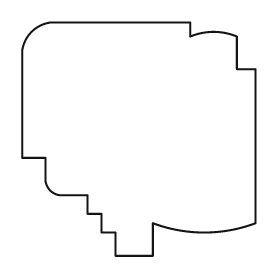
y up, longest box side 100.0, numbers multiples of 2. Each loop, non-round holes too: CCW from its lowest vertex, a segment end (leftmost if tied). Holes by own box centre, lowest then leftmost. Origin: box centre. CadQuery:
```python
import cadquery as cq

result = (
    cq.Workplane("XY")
    .moveTo(-10.0, -50.0)
    .lineTo(6.0, -50.0)
    .lineTo(6.0, -36.0)
    .threePointArc((28.0, -40.0), (50.0, -36.0))
    .lineTo(50.0, 30.0)
    .lineTo(42.0, 30.0)
    .lineTo(42.0, 44.0)
    .threePointArc((32.0, 46.0), (22.0, 44.0))
    .lineTo(22.0, 50.0)
    .lineTo(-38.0, 50.0)
    .threePointArc((-46.0, 46.0), (-50.0, 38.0))
    .lineTo(-50.0, -8.0)
    .lineTo(-40.0, -8.0)
    .lineTo(-40.0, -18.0)
    .threePointArc((-38.0, -22.0), (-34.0, -24.0))
    .lineTo(-22.0, -24.0)
    .lineTo(-22.0, -32.0)
    .lineTo(-16.0, -32.0)
    .lineTo(-16.0, -40.0)
    .lineTo(-10.0, -40.0)
    .close()
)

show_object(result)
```